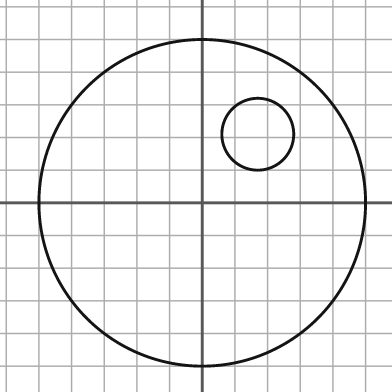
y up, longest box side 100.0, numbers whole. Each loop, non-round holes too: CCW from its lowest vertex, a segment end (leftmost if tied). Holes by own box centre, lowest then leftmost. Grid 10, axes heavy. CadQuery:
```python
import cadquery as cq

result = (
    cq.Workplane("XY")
    .moveTo(0.0, 0.0)
    .circle(50.0)
    .moveTo(17.0, 21.0)
    .circle(11.0)
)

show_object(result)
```